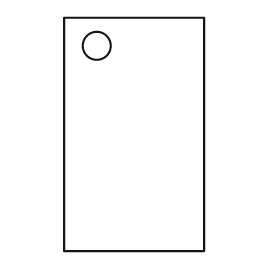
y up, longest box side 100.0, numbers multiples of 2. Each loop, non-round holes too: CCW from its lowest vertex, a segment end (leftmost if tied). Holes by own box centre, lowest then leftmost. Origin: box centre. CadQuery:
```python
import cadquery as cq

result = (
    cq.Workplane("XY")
    .moveTo(-30.0, -50.0)
    .lineTo(30.0, -50.0)
    .lineTo(30.0, 50.0)
    .lineTo(-30.0, 50.0)
    .close()
    .moveTo(-16.0, 38.0)
    .circle(6.0)
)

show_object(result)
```